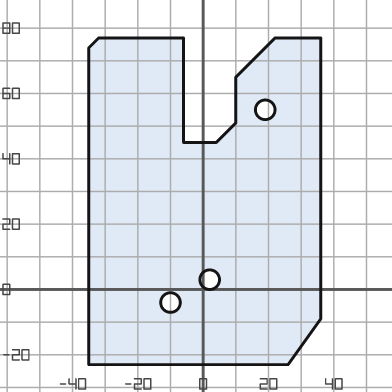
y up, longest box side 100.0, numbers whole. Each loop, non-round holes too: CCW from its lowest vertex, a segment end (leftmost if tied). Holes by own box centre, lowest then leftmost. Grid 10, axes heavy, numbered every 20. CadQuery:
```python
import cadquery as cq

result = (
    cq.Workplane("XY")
    .moveTo(-35.0, -23.0)
    .lineTo(26.0, -23.0)
    .lineTo(36.0, -9.0)
    .lineTo(36.0, 77.0)
    .lineTo(22.0, 77.0)
    .lineTo(10.0, 65.0)
    .lineTo(10.0, 51.0)
    .lineTo(4.0, 45.0)
    .lineTo(-6.0, 45.0)
    .lineTo(-6.0, 77.0)
    .lineTo(-32.0, 77.0)
    .lineTo(-35.0, 74.0)
    .close()
    .moveTo(-10.0, -4.0)
    .circle(3.0)
    .moveTo(2.0, 3.0)
    .circle(3.0)
    .moveTo(19.0, 55.0)
    .circle(3.0)
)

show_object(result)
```